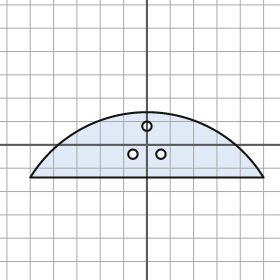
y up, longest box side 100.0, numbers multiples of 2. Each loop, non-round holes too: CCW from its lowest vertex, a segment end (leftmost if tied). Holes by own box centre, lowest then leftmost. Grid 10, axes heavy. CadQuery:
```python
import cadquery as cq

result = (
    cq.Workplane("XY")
    .moveTo(-50.0, -14.0)
    .lineTo(50.0, -14.0)
    .threePointArc((0.0, 14.0), (-50.0, -14.0))
    .close()
    .moveTo(-6.0, -4.0)
    .circle(2.0)
    .moveTo(6.0, -4.0)
    .circle(2.0)
    .moveTo(0.0, 8.0)
    .circle(2.0)
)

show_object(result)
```